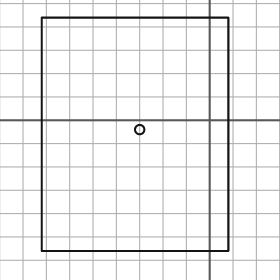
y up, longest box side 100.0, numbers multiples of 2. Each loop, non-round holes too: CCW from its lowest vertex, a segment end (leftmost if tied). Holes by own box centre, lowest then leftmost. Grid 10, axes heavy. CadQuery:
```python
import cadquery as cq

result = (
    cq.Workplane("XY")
    .moveTo(-72.0, -56.0)
    .lineTo(8.0, -56.0)
    .lineTo(8.0, 44.0)
    .lineTo(-72.0, 44.0)
    .close()
    .moveTo(-30.0, -4.0)
    .circle(2.0)
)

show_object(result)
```